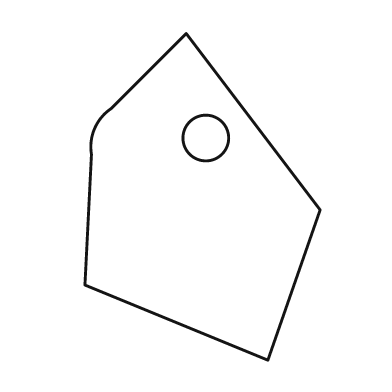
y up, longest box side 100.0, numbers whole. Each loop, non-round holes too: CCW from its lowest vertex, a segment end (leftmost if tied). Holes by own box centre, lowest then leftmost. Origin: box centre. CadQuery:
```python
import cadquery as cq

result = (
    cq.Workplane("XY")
    .moveTo(20.0, -50.0)
    .lineTo(36.0, -4.0)
    .lineTo(-5.0, 50.0)
    .lineTo(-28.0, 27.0)
    .threePointArc((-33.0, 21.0), (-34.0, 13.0))
    .lineTo(-36.0, -27.0)
    .close()
    .moveTo(1.0, 18.0)
    .circle(7.0)
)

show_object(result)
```